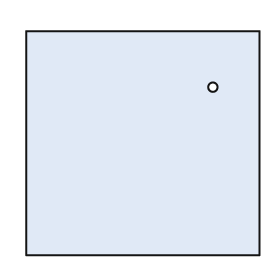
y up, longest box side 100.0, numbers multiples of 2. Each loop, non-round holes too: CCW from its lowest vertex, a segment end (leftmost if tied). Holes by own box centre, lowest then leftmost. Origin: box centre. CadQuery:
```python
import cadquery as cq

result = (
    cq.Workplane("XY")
    .moveTo(-50.0, -48.0)
    .lineTo(50.0, -48.0)
    .lineTo(50.0, 48.0)
    .lineTo(-50.0, 48.0)
    .close()
    .moveTo(30.0, 24.0)
    .circle(2.0)
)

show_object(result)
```